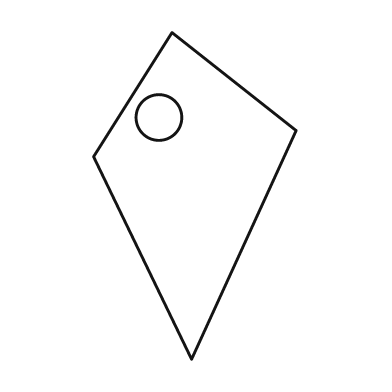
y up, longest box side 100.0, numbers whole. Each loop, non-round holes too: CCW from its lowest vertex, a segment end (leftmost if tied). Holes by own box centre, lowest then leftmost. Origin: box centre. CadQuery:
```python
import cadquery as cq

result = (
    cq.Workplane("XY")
    .moveTo(-1.0, -50.0)
    .lineTo(31.0, 20.0)
    .lineTo(-7.0, 50.0)
    .lineTo(-31.0, 12.0)
    .close()
    .moveTo(-11.0, 24.0)
    .circle(7.0)
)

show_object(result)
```